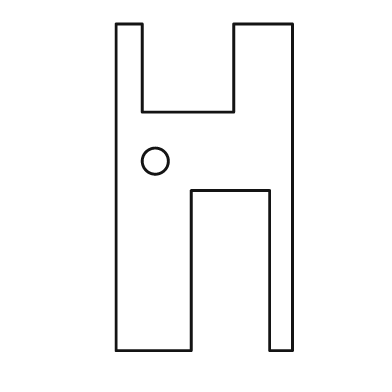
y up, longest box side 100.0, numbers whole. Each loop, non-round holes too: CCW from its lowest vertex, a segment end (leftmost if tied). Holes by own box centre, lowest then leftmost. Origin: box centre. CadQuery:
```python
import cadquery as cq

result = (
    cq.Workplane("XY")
    .moveTo(-27.0, -50.0)
    .lineTo(-4.0, -50.0)
    .lineTo(-4.0, -1.0)
    .lineTo(20.0, -1.0)
    .lineTo(20.0, -50.0)
    .lineTo(27.0, -50.0)
    .lineTo(27.0, 50.0)
    .lineTo(9.0, 50.0)
    .lineTo(9.0, 23.0)
    .lineTo(-19.0, 23.0)
    .lineTo(-19.0, 50.0)
    .lineTo(-27.0, 50.0)
    .close()
    .moveTo(-15.0, 8.0)
    .circle(4.0)
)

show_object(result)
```